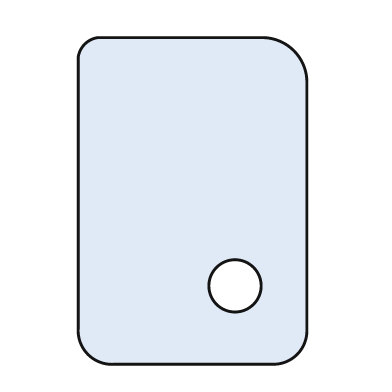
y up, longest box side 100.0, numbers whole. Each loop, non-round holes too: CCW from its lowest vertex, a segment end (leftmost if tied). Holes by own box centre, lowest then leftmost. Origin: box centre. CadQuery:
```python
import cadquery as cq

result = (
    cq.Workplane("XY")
    .moveTo(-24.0, -50.0)
    .lineTo(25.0, -50.0)
    .threePointArc((32.0, -47.0), (35.0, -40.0))
    .lineTo(35.0, 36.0)
    .threePointArc((31.0, 46.0), (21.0, 50.0))
    .lineTo(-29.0, 50.0)
    .threePointArc((-33.0, 48.0), (-35.0, 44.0))
    .lineTo(-35.0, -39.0)
    .threePointArc((-32.0, -47.0), (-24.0, -50.0))
    .close()
    .moveTo(13.0, -26.0)
    .circle(8.0)
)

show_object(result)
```